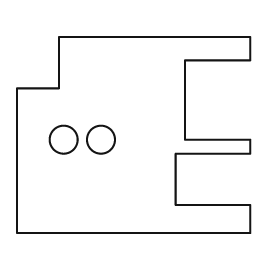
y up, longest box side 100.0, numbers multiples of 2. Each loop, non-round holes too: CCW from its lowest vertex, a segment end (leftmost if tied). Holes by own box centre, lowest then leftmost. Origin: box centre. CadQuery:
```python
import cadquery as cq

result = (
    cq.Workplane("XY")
    .moveTo(-50.0, -42.0)
    .lineTo(50.0, -42.0)
    .lineTo(50.0, -30.0)
    .lineTo(18.0, -30.0)
    .lineTo(18.0, -8.0)
    .lineTo(50.0, -8.0)
    .lineTo(50.0, -2.0)
    .lineTo(22.0, -2.0)
    .lineTo(22.0, 32.0)
    .lineTo(50.0, 32.0)
    .lineTo(50.0, 42.0)
    .lineTo(-32.0, 42.0)
    .lineTo(-32.0, 20.0)
    .lineTo(-50.0, 20.0)
    .close()
    .moveTo(-30.0, -2.0)
    .circle(6.0)
    .moveTo(-14.0, -2.0)
    .circle(6.0)
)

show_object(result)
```